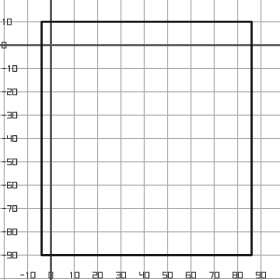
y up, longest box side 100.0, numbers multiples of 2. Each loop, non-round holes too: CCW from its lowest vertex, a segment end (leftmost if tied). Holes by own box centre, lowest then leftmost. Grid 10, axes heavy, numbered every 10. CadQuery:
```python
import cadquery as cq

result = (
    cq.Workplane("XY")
    .moveTo(-4.0, -90.0)
    .lineTo(86.0, -90.0)
    .lineTo(86.0, 10.0)
    .lineTo(-4.0, 10.0)
    .close()
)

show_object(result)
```